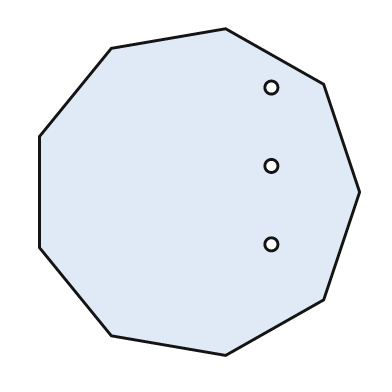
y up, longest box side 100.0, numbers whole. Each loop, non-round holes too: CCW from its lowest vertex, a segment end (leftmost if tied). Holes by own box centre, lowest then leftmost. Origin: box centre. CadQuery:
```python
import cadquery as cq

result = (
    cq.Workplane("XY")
    .moveTo(8.0, -50.0)
    .lineTo(38.0, -33.0)
    .lineTo(49.0, 0.0)
    .lineTo(38.0, 33.0)
    .lineTo(8.0, 50.0)
    .lineTo(-27.0, 44.0)
    .lineTo(-49.0, 17.0)
    .lineTo(-49.0, -17.0)
    .lineTo(-27.0, -44.0)
    .close()
    .moveTo(22.0, -16.0)
    .circle(2.0)
    .moveTo(22.0, 8.0)
    .circle(2.0)
    .moveTo(22.0, 32.0)
    .circle(2.0)
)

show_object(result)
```